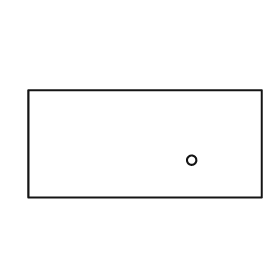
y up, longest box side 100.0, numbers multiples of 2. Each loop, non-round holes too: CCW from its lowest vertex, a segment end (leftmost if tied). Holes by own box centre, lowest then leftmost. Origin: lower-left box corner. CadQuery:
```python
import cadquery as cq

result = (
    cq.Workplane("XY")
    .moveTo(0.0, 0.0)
    .lineTo(100.0, 0.0)
    .lineTo(100.0, 46.0)
    .lineTo(0.0, 46.0)
    .close()
    .moveTo(70.0, 16.0)
    .circle(2.0)
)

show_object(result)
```